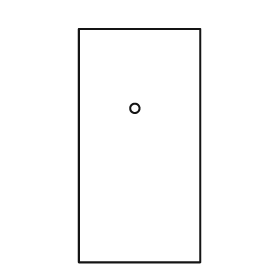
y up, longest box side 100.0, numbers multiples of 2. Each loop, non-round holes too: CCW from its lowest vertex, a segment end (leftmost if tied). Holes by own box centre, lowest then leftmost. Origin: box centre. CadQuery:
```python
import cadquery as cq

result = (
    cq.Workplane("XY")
    .moveTo(-26.0, -50.0)
    .lineTo(26.0, -50.0)
    .lineTo(26.0, 50.0)
    .lineTo(-26.0, 50.0)
    .close()
    .moveTo(-2.0, 16.0)
    .circle(2.0)
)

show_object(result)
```